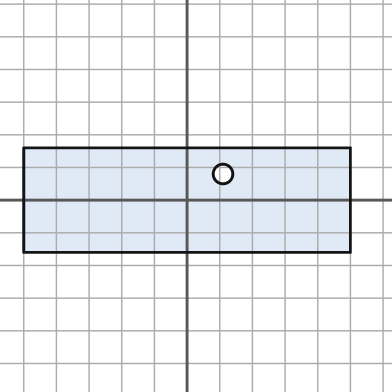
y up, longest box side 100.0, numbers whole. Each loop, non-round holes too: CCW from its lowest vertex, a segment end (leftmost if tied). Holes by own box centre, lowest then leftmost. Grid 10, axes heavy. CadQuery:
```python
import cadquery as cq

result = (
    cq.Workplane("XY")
    .moveTo(-50.0, -16.0)
    .lineTo(50.0, -16.0)
    .lineTo(50.0, 16.0)
    .lineTo(-50.0, 16.0)
    .close()
    .moveTo(11.0, 8.0)
    .circle(3.0)
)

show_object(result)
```